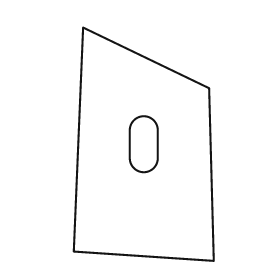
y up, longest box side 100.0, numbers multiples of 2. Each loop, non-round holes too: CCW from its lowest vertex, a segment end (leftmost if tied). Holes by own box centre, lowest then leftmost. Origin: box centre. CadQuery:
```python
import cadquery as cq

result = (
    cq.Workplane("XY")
    .moveTo(30.0, -50.0)
    .lineTo(28.0, 24.0)
    .lineTo(-26.0, 50.0)
    .lineTo(-30.0, -46.0)
    .close()
    .moveTo(-6.0, -6.0)
    .threePointArc((0.0, -12.0), (6.0, -6.0))
    .lineTo(6.0, 6.0)
    .threePointArc((0.0, 12.0), (-6.0, 6.0))
    .close()
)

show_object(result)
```